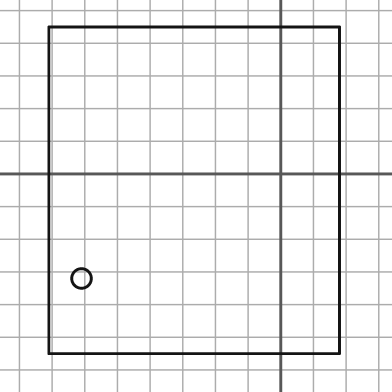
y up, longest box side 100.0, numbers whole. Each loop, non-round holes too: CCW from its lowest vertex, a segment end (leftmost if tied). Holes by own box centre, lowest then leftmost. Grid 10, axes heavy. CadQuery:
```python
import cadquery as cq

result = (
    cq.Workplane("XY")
    .moveTo(-71.0, -55.0)
    .lineTo(18.0, -55.0)
    .lineTo(18.0, 45.0)
    .lineTo(-71.0, 45.0)
    .close()
    .moveTo(-61.0, -32.0)
    .circle(3.0)
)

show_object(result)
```